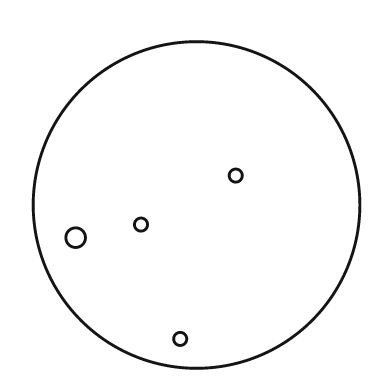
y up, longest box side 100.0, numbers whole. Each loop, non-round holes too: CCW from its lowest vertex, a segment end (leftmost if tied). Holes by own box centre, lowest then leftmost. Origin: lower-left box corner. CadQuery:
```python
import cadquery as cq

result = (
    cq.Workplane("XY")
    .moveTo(50.0, 50.0)
    .circle(50.0)
    .moveTo(45.0, 9.0)
    .circle(2.0)
    .moveTo(13.0, 40.0)
    .circle(3.0)
    .moveTo(33.0, 44.0)
    .circle(2.0)
    .moveTo(62.0, 59.0)
    .circle(2.0)
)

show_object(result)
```